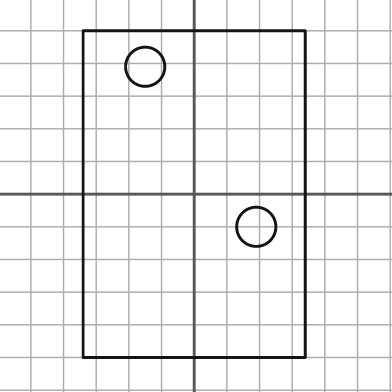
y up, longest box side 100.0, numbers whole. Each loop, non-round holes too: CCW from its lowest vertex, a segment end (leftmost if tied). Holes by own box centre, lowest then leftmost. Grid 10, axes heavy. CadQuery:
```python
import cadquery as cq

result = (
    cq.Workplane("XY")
    .moveTo(-34.0, -50.0)
    .lineTo(34.0, -50.0)
    .lineTo(34.0, 50.0)
    .lineTo(-34.0, 50.0)
    .close()
    .moveTo(19.0, -10.0)
    .circle(6.0)
    .moveTo(-15.0, 39.0)
    .circle(6.0)
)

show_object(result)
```